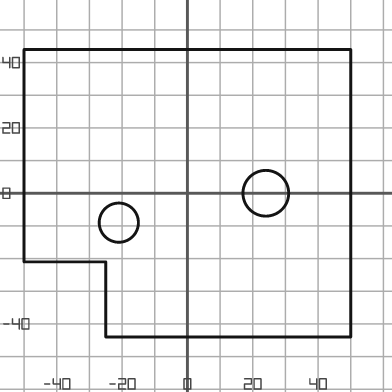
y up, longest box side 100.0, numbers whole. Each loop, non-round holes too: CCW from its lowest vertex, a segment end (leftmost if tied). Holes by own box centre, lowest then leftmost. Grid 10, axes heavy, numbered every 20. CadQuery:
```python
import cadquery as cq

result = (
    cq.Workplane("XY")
    .moveTo(-25.0, -44.0)
    .lineTo(50.0, -44.0)
    .lineTo(50.0, 44.0)
    .lineTo(-50.0, 44.0)
    .lineTo(-50.0, -21.0)
    .lineTo(-25.0, -21.0)
    .close()
    .moveTo(-21.0, -9.0)
    .circle(6.0)
    .moveTo(24.0, 0.0)
    .circle(7.0)
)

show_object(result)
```